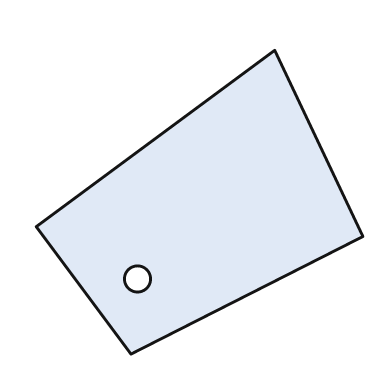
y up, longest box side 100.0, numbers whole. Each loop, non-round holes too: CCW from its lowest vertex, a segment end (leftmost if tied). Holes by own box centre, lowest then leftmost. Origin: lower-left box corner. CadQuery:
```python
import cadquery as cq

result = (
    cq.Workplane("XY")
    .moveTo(29.0, 0.0)
    .lineTo(100.0, 36.0)
    .lineTo(73.0, 93.0)
    .lineTo(0.0, 39.0)
    .close()
    .moveTo(31.0, 23.0)
    .circle(4.0)
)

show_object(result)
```